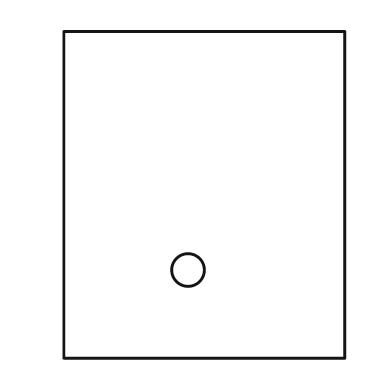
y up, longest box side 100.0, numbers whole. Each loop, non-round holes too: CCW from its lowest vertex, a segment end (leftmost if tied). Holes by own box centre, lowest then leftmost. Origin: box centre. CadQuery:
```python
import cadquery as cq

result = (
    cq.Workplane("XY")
    .moveTo(-43.0, -50.0)
    .lineTo(43.0, -50.0)
    .lineTo(43.0, 50.0)
    .lineTo(-43.0, 50.0)
    .close()
    .moveTo(-5.0, -23.0)
    .circle(5.0)
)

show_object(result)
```